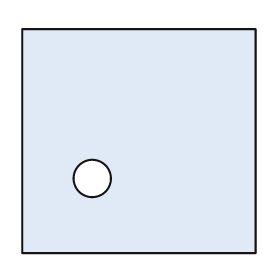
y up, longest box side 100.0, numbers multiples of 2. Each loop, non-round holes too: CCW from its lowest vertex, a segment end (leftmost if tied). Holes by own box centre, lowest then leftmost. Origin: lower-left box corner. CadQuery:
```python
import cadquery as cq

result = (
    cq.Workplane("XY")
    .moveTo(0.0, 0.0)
    .lineTo(100.0, 0.0)
    .lineTo(100.0, 96.0)
    .lineTo(0.0, 96.0)
    .close()
    .moveTo(30.0, 32.0)
    .circle(8.0)
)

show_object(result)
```